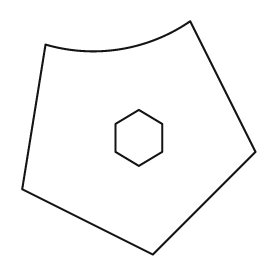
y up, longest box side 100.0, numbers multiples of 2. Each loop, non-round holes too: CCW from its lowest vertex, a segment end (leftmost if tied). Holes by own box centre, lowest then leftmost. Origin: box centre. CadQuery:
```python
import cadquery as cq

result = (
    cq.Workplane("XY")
    .moveTo(6.0, -50.0)
    .lineTo(50.0, -6.0)
    .lineTo(22.0, 50.0)
    .threePointArc((-8.0, 38.0), (-40.0, 40.0))
    .lineTo(-50.0, -22.0)
    .close()
    .moveTo(0.0, -12.0)
    .lineTo(10.0, -6.0)
    .lineTo(10.0, 6.0)
    .lineTo(0.0, 12.0)
    .lineTo(-10.0, 6.0)
    .lineTo(-10.0, -6.0)
    .close()
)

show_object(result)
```